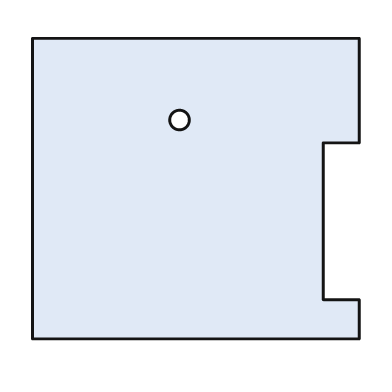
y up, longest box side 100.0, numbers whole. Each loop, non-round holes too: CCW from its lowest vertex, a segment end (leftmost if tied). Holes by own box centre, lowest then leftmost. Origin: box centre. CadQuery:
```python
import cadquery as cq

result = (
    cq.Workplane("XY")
    .moveTo(-50.0, -46.0)
    .lineTo(50.0, -46.0)
    .lineTo(50.0, -34.0)
    .lineTo(39.0, -34.0)
    .lineTo(39.0, 14.0)
    .lineTo(50.0, 14.0)
    .lineTo(50.0, 46.0)
    .lineTo(-50.0, 46.0)
    .close()
    .moveTo(-5.0, 21.0)
    .circle(3.0)
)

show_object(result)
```